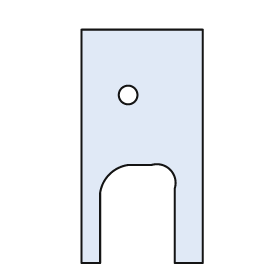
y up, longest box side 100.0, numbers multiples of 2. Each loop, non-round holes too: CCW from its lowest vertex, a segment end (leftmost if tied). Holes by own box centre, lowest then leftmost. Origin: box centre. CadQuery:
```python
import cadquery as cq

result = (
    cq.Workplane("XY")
    .moveTo(-26.0, -50.0)
    .lineTo(-18.0, -50.0)
    .lineTo(-18.0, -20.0)
    .threePointArc((-14.0, -12.0), (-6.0, -8.0))
    .lineTo(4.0, -8.0)
    .threePointArc((12.0, -10.0), (14.0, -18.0))
    .lineTo(14.0, -50.0)
    .lineTo(26.0, -50.0)
    .lineTo(26.0, 50.0)
    .lineTo(-26.0, 50.0)
    .close()
    .moveTo(-6.0, 22.0)
    .circle(4.0)
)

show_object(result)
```